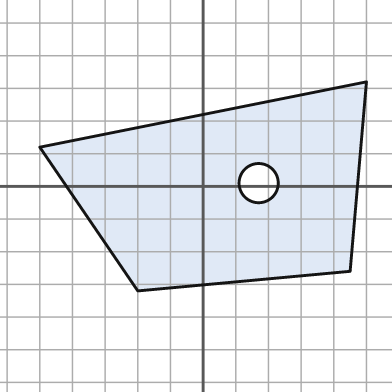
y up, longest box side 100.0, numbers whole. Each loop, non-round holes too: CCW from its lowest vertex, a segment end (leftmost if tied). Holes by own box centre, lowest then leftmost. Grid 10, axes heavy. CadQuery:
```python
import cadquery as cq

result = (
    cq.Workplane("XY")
    .moveTo(-20.0, -32.0)
    .lineTo(45.0, -26.0)
    .lineTo(50.0, 32.0)
    .lineTo(-50.0, 12.0)
    .close()
    .moveTo(17.0, 1.0)
    .circle(6.0)
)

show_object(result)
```